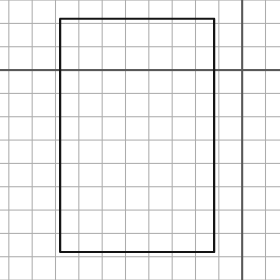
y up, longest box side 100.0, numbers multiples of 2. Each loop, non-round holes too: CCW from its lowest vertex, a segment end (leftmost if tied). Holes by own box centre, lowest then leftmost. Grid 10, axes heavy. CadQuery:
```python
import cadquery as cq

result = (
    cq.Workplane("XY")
    .moveTo(-78.0, -78.0)
    .lineTo(-12.0, -78.0)
    .lineTo(-12.0, 22.0)
    .lineTo(-78.0, 22.0)
    .close()
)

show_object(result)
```